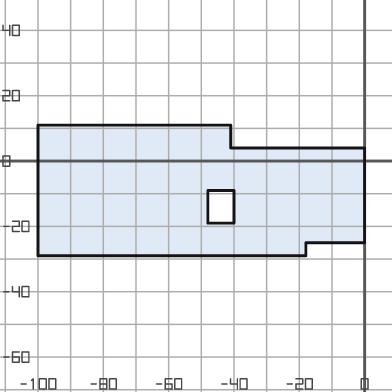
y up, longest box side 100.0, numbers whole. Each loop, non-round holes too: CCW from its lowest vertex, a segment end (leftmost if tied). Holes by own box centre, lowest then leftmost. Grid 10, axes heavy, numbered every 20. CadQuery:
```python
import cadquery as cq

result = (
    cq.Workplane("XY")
    .moveTo(-100.0, -29.0)
    .lineTo(-18.0, -29.0)
    .lineTo(-18.0, -25.0)
    .lineTo(0.0, -25.0)
    .lineTo(0.0, 4.0)
    .lineTo(-41.0, 4.0)
    .lineTo(-41.0, 11.0)
    .lineTo(-100.0, 11.0)
    .close()
    .moveTo(-48.0, -19.0)
    .lineTo(-40.0, -19.0)
    .lineTo(-40.0, -9.0)
    .lineTo(-48.0, -9.0)
    .close()
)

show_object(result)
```